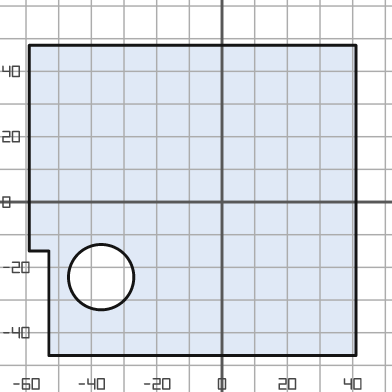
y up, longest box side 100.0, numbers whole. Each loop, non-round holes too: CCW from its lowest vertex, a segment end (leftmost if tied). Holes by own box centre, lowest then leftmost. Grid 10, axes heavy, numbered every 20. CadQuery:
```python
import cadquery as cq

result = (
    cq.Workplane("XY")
    .moveTo(-53.0, -47.0)
    .lineTo(41.0, -47.0)
    .lineTo(41.0, 48.0)
    .lineTo(-59.0, 48.0)
    .lineTo(-59.0, -15.0)
    .lineTo(-53.0, -15.0)
    .close()
    .moveTo(-37.0, -23.0)
    .circle(10.0)
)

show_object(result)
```